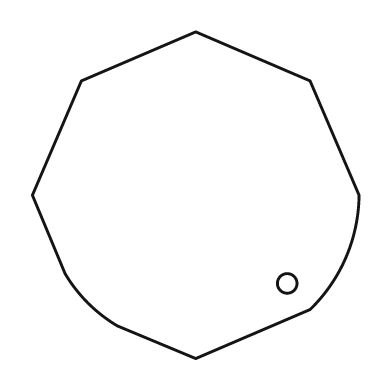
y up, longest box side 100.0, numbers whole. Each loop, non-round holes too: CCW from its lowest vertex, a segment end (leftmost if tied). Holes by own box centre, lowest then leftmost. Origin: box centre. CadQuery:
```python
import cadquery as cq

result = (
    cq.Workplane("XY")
    .moveTo(0.0, -50.0)
    .lineTo(35.0, -35.0)
    .threePointArc((46.0, -19.0), (50.0, 0.0))
    .lineTo(35.0, 35.0)
    .lineTo(0.0, 50.0)
    .lineTo(-35.0, 35.0)
    .lineTo(-50.0, 0.0)
    .lineTo(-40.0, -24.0)
    .threePointArc((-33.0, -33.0), (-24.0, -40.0))
    .close()
    .moveTo(28.0, -27.0)
    .circle(3.0)
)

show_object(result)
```